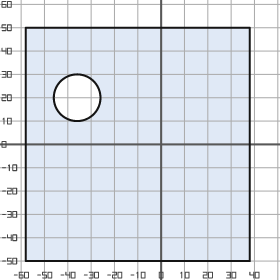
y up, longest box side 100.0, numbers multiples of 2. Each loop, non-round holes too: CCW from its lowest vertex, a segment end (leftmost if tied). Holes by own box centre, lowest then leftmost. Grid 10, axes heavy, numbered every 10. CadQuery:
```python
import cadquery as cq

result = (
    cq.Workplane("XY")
    .moveTo(-58.0, -50.0)
    .lineTo(38.0, -50.0)
    .lineTo(38.0, 50.0)
    .lineTo(-58.0, 50.0)
    .close()
    .moveTo(-36.0, 20.0)
    .circle(10.0)
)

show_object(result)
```